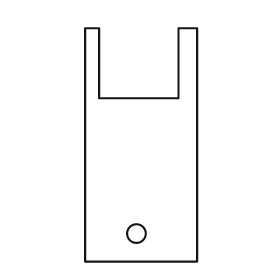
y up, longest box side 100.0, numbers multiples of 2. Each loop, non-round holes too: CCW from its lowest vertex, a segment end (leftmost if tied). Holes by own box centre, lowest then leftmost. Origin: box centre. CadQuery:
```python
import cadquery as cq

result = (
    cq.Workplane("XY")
    .moveTo(-24.0, -50.0)
    .lineTo(24.0, -50.0)
    .lineTo(24.0, 50.0)
    .lineTo(16.0, 50.0)
    .lineTo(16.0, 20.0)
    .lineTo(-18.0, 20.0)
    .lineTo(-18.0, 50.0)
    .lineTo(-24.0, 50.0)
    .close()
    .moveTo(-2.0, -38.0)
    .circle(4.0)
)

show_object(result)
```